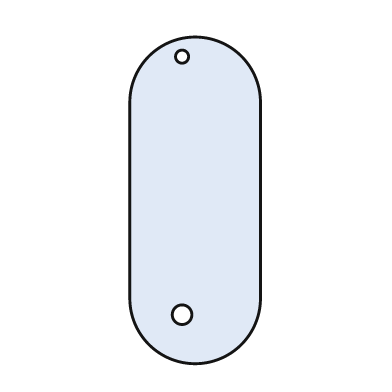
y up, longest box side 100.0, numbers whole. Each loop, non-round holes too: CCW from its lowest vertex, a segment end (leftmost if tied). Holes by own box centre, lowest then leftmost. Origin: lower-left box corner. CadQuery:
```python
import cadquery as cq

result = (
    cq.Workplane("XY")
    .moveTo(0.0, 20.0)
    .threePointArc((20.0, 0.0), (40.0, 20.0))
    .lineTo(40.0, 80.0)
    .threePointArc((20.0, 100.0), (0.0, 80.0))
    .close()
    .moveTo(16.0, 15.0)
    .circle(3.0)
    .moveTo(16.0, 94.0)
    .circle(2.0)
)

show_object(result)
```